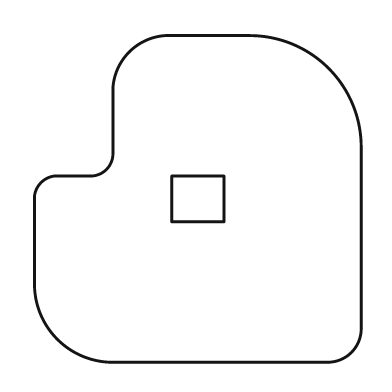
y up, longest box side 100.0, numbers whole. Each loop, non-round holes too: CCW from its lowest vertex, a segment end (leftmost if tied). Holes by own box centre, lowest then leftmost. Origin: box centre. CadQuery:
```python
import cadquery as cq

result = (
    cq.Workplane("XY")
    .moveTo(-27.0, -50.0)
    .lineTo(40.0, -50.0)
    .threePointArc((47.0, -47.0), (50.0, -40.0))
    .lineTo(50.0, 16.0)
    .threePointArc((40.0, 40.0), (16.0, 50.0))
    .lineTo(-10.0, 50.0)
    .threePointArc((-21.0, 45.0), (-26.0, 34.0))
    .lineTo(-26.0, 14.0)
    .threePointArc((-28.0, 9.0), (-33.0, 7.0))
    .lineTo(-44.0, 7.0)
    .threePointArc((-48.0, 5.0), (-50.0, 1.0))
    .lineTo(-50.0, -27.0)
    .threePointArc((-43.0, -43.0), (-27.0, -50.0))
    .close()
    .moveTo(-8.0, -7.0)
    .lineTo(8.0, -7.0)
    .lineTo(8.0, 7.0)
    .lineTo(-8.0, 7.0)
    .close()
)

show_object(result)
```